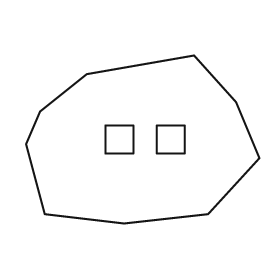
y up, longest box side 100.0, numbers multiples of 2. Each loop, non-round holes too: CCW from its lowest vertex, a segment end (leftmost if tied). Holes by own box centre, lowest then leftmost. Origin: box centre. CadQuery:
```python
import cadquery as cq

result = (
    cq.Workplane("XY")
    .moveTo(-8.0, -36.0)
    .lineTo(28.0, -32.0)
    .lineTo(50.0, -8.0)
    .lineTo(40.0, 16.0)
    .lineTo(22.0, 36.0)
    .lineTo(-24.0, 28.0)
    .lineTo(-44.0, 12.0)
    .lineTo(-50.0, -2.0)
    .lineTo(-42.0, -32.0)
    .close()
    .moveTo(-16.0, -6.0)
    .lineTo(-4.0, -6.0)
    .lineTo(-4.0, 6.0)
    .lineTo(-16.0, 6.0)
    .close()
    .moveTo(6.0, -6.0)
    .lineTo(18.0, -6.0)
    .lineTo(18.0, 6.0)
    .lineTo(6.0, 6.0)
    .close()
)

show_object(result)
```